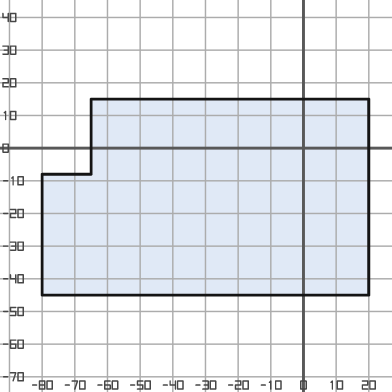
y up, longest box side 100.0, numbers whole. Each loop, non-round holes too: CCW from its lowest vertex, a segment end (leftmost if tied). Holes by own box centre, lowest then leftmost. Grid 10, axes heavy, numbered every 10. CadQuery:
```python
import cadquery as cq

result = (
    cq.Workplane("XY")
    .moveTo(-80.0, -45.0)
    .lineTo(20.0, -45.0)
    .lineTo(20.0, 15.0)
    .lineTo(-65.0, 15.0)
    .lineTo(-65.0, -8.0)
    .lineTo(-80.0, -8.0)
    .close()
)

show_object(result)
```